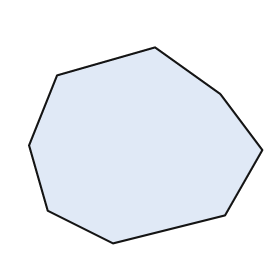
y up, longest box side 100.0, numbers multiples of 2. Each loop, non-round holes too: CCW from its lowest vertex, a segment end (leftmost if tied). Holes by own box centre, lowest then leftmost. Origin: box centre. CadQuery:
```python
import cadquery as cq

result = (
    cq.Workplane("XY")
    .moveTo(-14.0, -42.0)
    .lineTo(34.0, -30.0)
    .lineTo(50.0, -2.0)
    .lineTo(32.0, 22.0)
    .lineTo(4.0, 42.0)
    .lineTo(-38.0, 30.0)
    .lineTo(-50.0, 0.0)
    .lineTo(-42.0, -28.0)
    .close()
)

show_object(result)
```